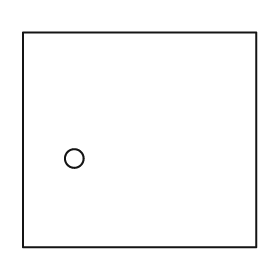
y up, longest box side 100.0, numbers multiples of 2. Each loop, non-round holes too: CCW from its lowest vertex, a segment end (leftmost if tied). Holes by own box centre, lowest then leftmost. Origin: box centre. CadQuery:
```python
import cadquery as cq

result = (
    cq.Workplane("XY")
    .moveTo(-50.0, -46.0)
    .lineTo(50.0, -46.0)
    .lineTo(50.0, 46.0)
    .lineTo(-50.0, 46.0)
    .close()
    .moveTo(-28.0, -8.0)
    .circle(4.0)
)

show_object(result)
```